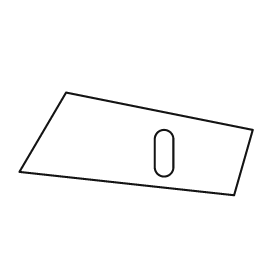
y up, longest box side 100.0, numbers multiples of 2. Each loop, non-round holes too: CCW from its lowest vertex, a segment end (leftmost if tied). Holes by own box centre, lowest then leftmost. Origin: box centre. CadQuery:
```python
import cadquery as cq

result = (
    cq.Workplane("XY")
    .moveTo(42.0, -22.0)
    .lineTo(50.0, 6.0)
    .lineTo(-30.0, 22.0)
    .lineTo(-50.0, -12.0)
    .close()
    .moveTo(8.0, -10.0)
    .threePointArc((12.0, -14.0), (16.0, -10.0))
    .lineTo(16.0, 2.0)
    .threePointArc((12.0, 6.0), (8.0, 2.0))
    .close()
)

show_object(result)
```